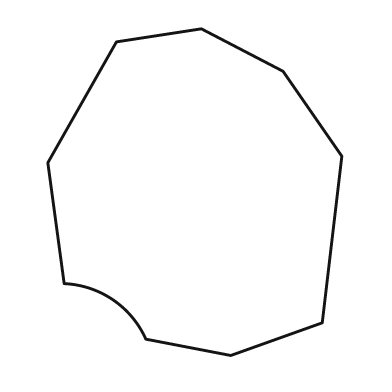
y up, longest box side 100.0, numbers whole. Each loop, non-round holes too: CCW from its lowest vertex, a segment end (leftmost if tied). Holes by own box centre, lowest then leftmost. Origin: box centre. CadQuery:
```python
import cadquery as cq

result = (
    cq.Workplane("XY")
    .moveTo(11.0, -50.0)
    .lineTo(39.0, -40.0)
    .lineTo(45.0, 11.0)
    .lineTo(27.0, 37.0)
    .lineTo(2.0, 50.0)
    .lineTo(-24.0, 46.0)
    .lineTo(-45.0, 9.0)
    .lineTo(-40.0, -28.0)
    .threePointArc((-25.0, -33.0), (-15.0, -45.0))
    .close()
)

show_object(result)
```